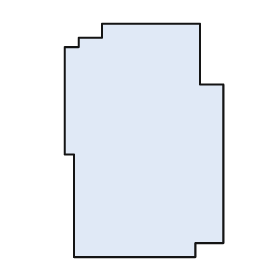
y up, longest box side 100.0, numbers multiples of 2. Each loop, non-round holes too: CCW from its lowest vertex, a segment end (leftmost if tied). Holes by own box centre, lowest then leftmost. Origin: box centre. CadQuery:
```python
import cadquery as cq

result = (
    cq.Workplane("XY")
    .moveTo(-30.0, -50.0)
    .lineTo(22.0, -50.0)
    .lineTo(22.0, -44.0)
    .lineTo(34.0, -44.0)
    .lineTo(34.0, 24.0)
    .lineTo(24.0, 24.0)
    .lineTo(24.0, 50.0)
    .lineTo(-18.0, 50.0)
    .lineTo(-18.0, 44.0)
    .lineTo(-28.0, 44.0)
    .lineTo(-28.0, 40.0)
    .lineTo(-34.0, 40.0)
    .lineTo(-34.0, -6.0)
    .lineTo(-30.0, -6.0)
    .close()
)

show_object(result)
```